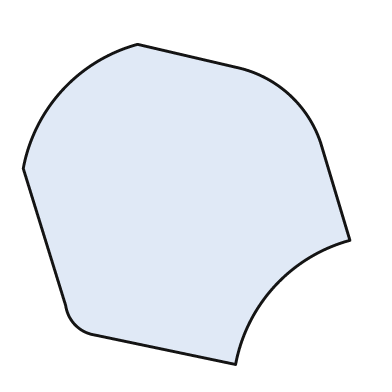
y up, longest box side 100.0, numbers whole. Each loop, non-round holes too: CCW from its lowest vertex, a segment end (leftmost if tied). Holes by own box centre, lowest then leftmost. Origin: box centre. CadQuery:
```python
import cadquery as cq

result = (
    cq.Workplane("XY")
    .moveTo(15.0, -49.0)
    .threePointArc((27.0, -25.0), (50.0, -11.0))
    .lineTo(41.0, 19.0)
    .threePointArc((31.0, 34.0), (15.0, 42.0))
    .lineTo(-15.0, 49.0)
    .threePointArc((-38.0, 35.0), (-50.0, 11.0))
    .lineTo(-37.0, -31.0)
    .threePointArc((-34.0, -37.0), (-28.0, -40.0))
    .close()
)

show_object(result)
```